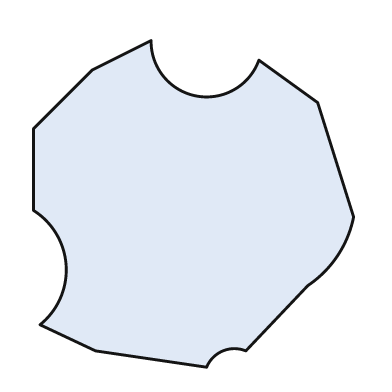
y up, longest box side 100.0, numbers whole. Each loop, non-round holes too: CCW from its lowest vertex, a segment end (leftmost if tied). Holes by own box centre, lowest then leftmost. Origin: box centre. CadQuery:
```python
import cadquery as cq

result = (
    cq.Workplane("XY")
    .moveTo(4.0, -50.0)
    .threePointArc((9.0, -45.0), (16.0, -45.0))
    .lineTo(35.0, -25.0)
    .threePointArc((44.0, -16.0), (49.0, -4.0))
    .lineTo(38.0, 31.0)
    .lineTo(20.0, 44.0)
    .threePointArc((1.0, 33.0), (-13.0, 50.0))
    .lineTo(-31.0, 41.0)
    .lineTo(-49.0, 23.0)
    .lineTo(-49.0, -2.0)
    .threePointArc((-39.0, -19.0), (-47.0, -37.0))
    .lineTo(-30.0, -45.0)
    .close()
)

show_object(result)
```